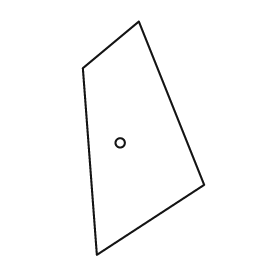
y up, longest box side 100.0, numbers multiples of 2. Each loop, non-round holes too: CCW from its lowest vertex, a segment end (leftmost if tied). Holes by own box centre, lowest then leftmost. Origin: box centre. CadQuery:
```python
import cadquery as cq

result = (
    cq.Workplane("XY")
    .moveTo(-20.0, -50.0)
    .lineTo(26.0, -20.0)
    .lineTo(-2.0, 50.0)
    .lineTo(-26.0, 30.0)
    .close()
    .moveTo(-10.0, -2.0)
    .circle(2.0)
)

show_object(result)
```